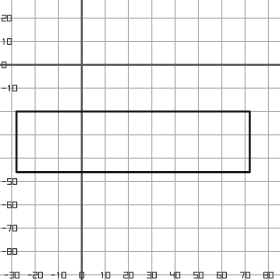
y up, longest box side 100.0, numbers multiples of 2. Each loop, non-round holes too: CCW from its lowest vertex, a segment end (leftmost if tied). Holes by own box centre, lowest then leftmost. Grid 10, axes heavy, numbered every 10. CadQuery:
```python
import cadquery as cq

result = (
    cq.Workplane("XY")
    .moveTo(-28.0, -46.0)
    .lineTo(72.0, -46.0)
    .lineTo(72.0, -20.0)
    .lineTo(-28.0, -20.0)
    .close()
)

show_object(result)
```